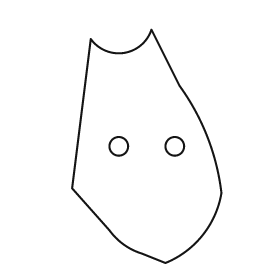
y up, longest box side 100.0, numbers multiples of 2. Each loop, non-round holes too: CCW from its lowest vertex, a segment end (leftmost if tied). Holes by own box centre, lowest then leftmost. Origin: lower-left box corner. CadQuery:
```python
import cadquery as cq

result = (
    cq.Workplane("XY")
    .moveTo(40.0, 0.0)
    .threePointArc((56.0, 12.0), (64.0, 30.0))
    .threePointArc((58.0, 54.0), (46.0, 76.0))
    .lineTo(34.0, 100.0)
    .threePointArc((22.0, 90.0), (8.0, 96.0))
    .lineTo(0.0, 32.0)
    .lineTo(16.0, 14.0)
    .threePointArc((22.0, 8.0), (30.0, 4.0))
    .close()
    .moveTo(20.0, 50.0)
    .circle(4.0)
    .moveTo(44.0, 50.0)
    .circle(4.0)
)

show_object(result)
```